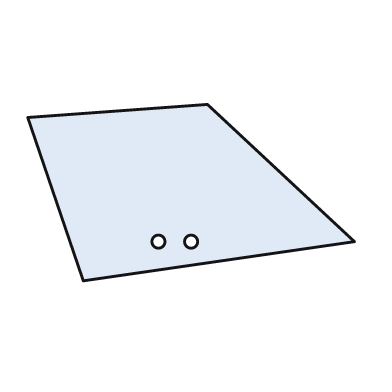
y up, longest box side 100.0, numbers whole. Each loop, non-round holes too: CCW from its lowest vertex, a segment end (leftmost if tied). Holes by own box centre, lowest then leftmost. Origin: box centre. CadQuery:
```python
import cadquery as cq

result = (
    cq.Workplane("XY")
    .moveTo(-33.0, -27.0)
    .lineTo(50.0, -15.0)
    .lineTo(5.0, 27.0)
    .lineTo(-50.0, 23.0)
    .close()
    .moveTo(-10.0, -15.0)
    .circle(2.0)
    .moveTo(0.0, -15.0)
    .circle(2.0)
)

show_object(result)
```